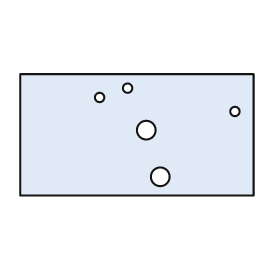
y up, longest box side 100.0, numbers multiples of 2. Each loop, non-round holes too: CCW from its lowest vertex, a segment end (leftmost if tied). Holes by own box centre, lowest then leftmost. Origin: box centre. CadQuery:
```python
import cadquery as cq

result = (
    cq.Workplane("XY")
    .moveTo(-50.0, -26.0)
    .lineTo(50.0, -26.0)
    .lineTo(50.0, 26.0)
    .lineTo(-50.0, 26.0)
    .close()
    .moveTo(10.0, -18.0)
    .circle(4.0)
    .moveTo(4.0, 2.0)
    .circle(4.0)
    .moveTo(42.0, 10.0)
    .circle(2.0)
    .moveTo(-16.0, 16.0)
    .circle(2.0)
    .moveTo(-4.0, 20.0)
    .circle(2.0)
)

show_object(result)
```